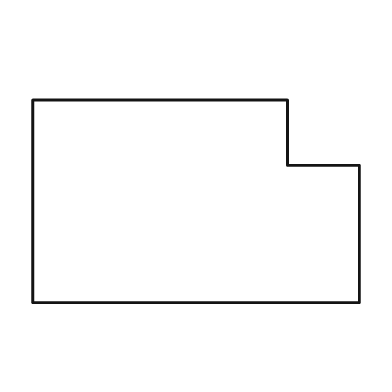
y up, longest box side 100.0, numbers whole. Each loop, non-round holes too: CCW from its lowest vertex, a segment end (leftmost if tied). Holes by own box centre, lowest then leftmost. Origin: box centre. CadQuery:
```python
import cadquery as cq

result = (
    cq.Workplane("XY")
    .moveTo(-50.0, -31.0)
    .lineTo(50.0, -31.0)
    .lineTo(50.0, 11.0)
    .lineTo(28.0, 11.0)
    .lineTo(28.0, 31.0)
    .lineTo(-50.0, 31.0)
    .close()
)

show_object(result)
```